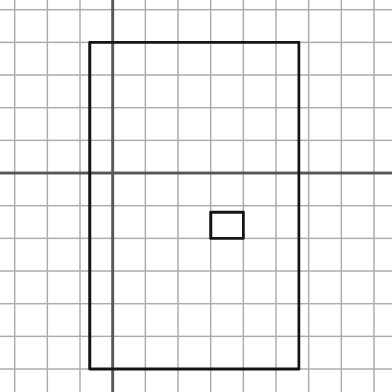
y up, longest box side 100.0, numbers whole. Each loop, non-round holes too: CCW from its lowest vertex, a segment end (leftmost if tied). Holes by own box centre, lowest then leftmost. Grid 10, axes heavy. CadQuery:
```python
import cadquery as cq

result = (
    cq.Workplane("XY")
    .moveTo(-7.0, -60.0)
    .lineTo(57.0, -60.0)
    .lineTo(57.0, 40.0)
    .lineTo(-7.0, 40.0)
    .close()
    .moveTo(30.0, -20.0)
    .lineTo(40.0, -20.0)
    .lineTo(40.0, -12.0)
    .lineTo(30.0, -12.0)
    .close()
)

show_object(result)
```